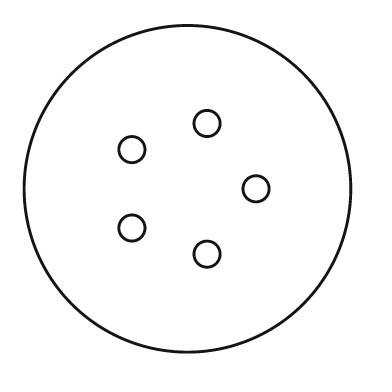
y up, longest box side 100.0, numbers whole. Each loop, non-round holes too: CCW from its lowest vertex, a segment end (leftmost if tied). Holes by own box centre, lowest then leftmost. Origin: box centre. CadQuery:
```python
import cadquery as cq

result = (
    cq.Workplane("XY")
    .moveTo(0.0, 0.0)
    .circle(50.0)
    .moveTo(6.0, -20.0)
    .circle(4.0)
    .moveTo(-17.0, -12.0)
    .circle(4.0)
    .moveTo(21.0, 0.0)
    .circle(4.0)
    .moveTo(-17.0, 12.0)
    .circle(4.0)
    .moveTo(6.0, 20.0)
    .circle(4.0)
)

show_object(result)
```